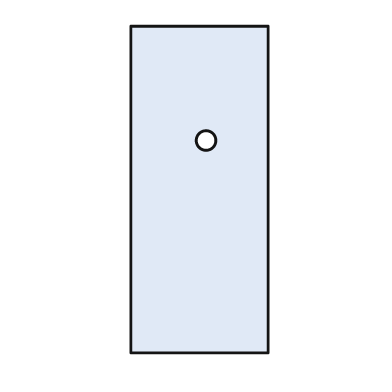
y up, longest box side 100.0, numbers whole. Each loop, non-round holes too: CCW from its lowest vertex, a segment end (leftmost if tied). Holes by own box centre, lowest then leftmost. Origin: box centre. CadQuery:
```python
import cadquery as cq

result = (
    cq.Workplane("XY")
    .moveTo(-21.0, -50.0)
    .lineTo(21.0, -50.0)
    .lineTo(21.0, 50.0)
    .lineTo(-21.0, 50.0)
    .close()
    .moveTo(2.0, 15.0)
    .circle(3.0)
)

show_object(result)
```